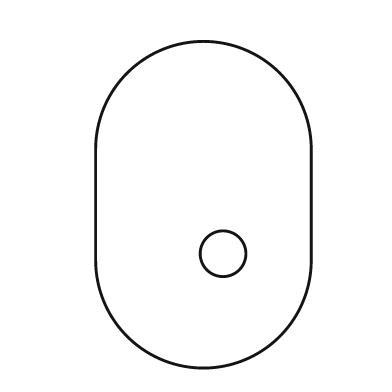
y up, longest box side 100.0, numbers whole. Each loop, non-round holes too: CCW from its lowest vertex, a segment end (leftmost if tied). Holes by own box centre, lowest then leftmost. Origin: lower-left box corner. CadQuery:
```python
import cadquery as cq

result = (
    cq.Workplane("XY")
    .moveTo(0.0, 33.0)
    .threePointArc((33.0, 0.0), (66.0, 33.0))
    .lineTo(66.0, 67.0)
    .threePointArc((33.0, 100.0), (0.0, 67.0))
    .close()
    .moveTo(39.0, 35.0)
    .circle(7.0)
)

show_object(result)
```